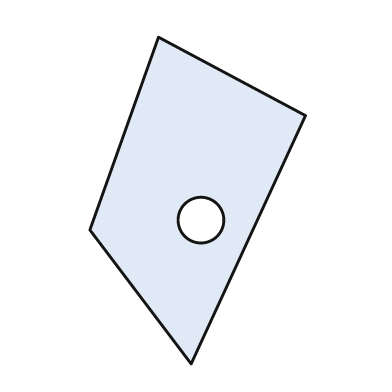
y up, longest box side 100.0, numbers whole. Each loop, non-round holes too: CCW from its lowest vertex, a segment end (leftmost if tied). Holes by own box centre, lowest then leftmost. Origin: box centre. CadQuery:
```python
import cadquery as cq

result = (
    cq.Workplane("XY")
    .moveTo(-2.0, -50.0)
    .lineTo(33.0, 26.0)
    .lineTo(-12.0, 50.0)
    .lineTo(-33.0, -9.0)
    .close()
    .moveTo(1.0, -6.0)
    .circle(7.0)
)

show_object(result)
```